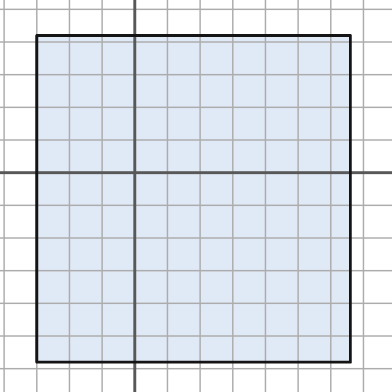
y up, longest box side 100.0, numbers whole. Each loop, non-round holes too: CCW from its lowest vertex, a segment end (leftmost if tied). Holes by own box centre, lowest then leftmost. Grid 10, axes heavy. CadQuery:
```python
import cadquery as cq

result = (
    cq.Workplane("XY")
    .moveTo(-30.0, -58.0)
    .lineTo(66.0, -58.0)
    .lineTo(66.0, 42.0)
    .lineTo(-30.0, 42.0)
    .close()
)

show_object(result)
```